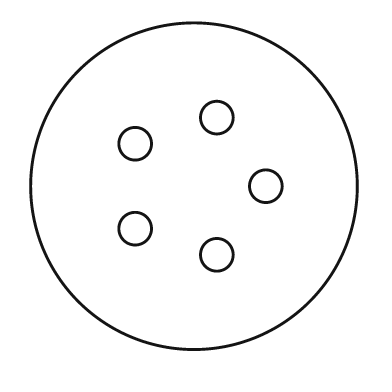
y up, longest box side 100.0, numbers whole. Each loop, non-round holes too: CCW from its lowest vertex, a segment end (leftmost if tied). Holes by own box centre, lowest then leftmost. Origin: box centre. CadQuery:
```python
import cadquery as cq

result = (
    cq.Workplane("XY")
    .moveTo(0.0, 0.0)
    .circle(50.0)
    .moveTo(7.0, -21.0)
    .circle(5.0)
    .moveTo(-18.0, -13.0)
    .circle(5.0)
    .moveTo(22.0, 0.0)
    .circle(5.0)
    .moveTo(-18.0, 13.0)
    .circle(5.0)
    .moveTo(7.0, 21.0)
    .circle(5.0)
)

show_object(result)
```